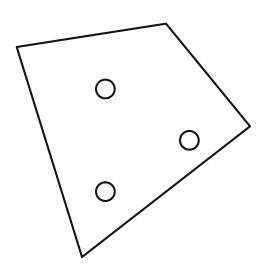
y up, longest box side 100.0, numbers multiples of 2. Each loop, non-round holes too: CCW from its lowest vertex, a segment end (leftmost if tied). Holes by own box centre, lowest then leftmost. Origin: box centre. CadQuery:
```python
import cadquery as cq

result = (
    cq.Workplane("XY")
    .moveTo(-22.0, -50.0)
    .lineTo(50.0, 6.0)
    .lineTo(14.0, 50.0)
    .lineTo(-50.0, 40.0)
    .close()
    .moveTo(-12.0, -22.0)
    .circle(4.0)
    .moveTo(24.0, 0.0)
    .circle(4.0)
    .moveTo(-12.0, 22.0)
    .circle(4.0)
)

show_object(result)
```